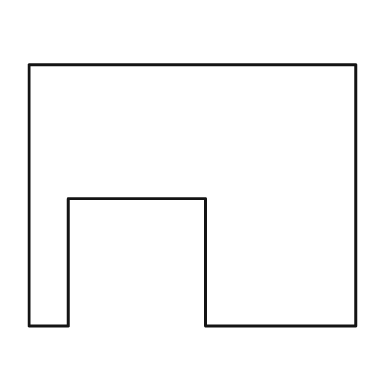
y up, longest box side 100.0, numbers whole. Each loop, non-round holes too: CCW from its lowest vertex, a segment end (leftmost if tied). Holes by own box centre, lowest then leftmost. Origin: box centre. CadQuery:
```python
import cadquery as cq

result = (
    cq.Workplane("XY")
    .moveTo(-50.0, -40.0)
    .lineTo(-38.0, -40.0)
    .lineTo(-38.0, -1.0)
    .lineTo(4.0, -1.0)
    .lineTo(4.0, -40.0)
    .lineTo(50.0, -40.0)
    .lineTo(50.0, 40.0)
    .lineTo(-50.0, 40.0)
    .close()
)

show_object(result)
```